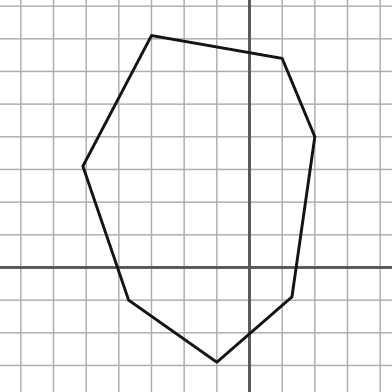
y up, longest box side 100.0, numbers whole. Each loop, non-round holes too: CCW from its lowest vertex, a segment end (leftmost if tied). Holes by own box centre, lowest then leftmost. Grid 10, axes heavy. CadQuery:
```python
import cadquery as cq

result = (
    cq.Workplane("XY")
    .moveTo(-10.0, -29.0)
    .lineTo(13.0, -9.0)
    .lineTo(20.0, 40.0)
    .lineTo(10.0, 64.0)
    .lineTo(-30.0, 71.0)
    .lineTo(-51.0, 31.0)
    .lineTo(-37.0, -10.0)
    .close()
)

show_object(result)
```